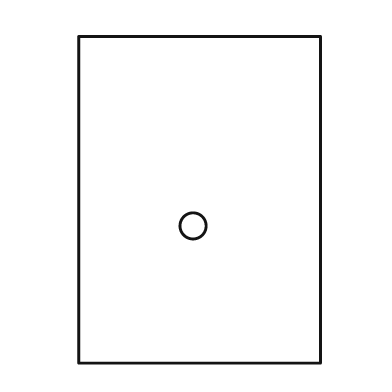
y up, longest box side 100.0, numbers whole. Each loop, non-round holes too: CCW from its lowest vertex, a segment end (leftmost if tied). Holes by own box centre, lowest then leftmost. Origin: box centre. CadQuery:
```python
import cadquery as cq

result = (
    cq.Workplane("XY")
    .moveTo(-37.0, -50.0)
    .lineTo(37.0, -50.0)
    .lineTo(37.0, 50.0)
    .lineTo(-37.0, 50.0)
    .close()
    .moveTo(-2.0, -8.0)
    .circle(4.0)
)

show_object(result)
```